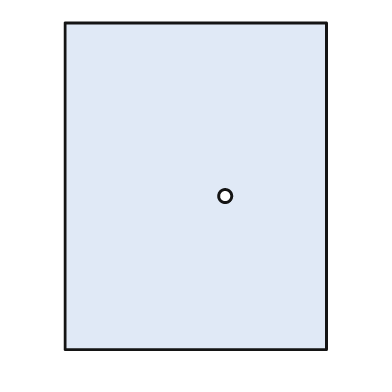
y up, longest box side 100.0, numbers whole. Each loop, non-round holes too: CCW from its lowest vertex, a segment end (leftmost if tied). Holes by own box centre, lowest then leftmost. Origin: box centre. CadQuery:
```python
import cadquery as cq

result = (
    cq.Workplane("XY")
    .moveTo(-40.0, -50.0)
    .lineTo(40.0, -50.0)
    .lineTo(40.0, 50.0)
    .lineTo(-40.0, 50.0)
    .close()
    .moveTo(9.0, -3.0)
    .circle(2.0)
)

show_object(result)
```